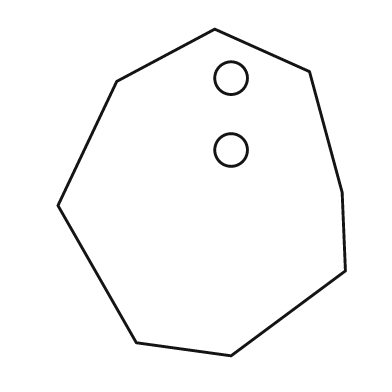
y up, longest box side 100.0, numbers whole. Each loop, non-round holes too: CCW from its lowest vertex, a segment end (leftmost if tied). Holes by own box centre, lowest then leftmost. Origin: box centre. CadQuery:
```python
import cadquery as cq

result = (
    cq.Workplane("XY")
    .moveTo(9.0, -50.0)
    .lineTo(44.0, -24.0)
    .lineTo(43.0, 0.0)
    .lineTo(33.0, 37.0)
    .lineTo(4.0, 50.0)
    .lineTo(-26.0, 34.0)
    .lineTo(-44.0, -4.0)
    .lineTo(-20.0, -46.0)
    .close()
    .moveTo(9.0, 13.0)
    .circle(5.0)
    .moveTo(9.0, 35.0)
    .circle(5.0)
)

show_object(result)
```